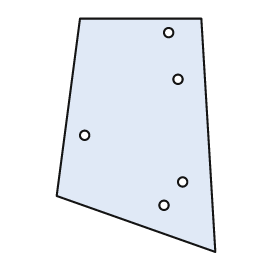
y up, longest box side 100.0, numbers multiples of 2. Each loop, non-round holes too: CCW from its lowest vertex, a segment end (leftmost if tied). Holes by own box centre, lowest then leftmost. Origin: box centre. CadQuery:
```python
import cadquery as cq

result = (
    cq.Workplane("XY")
    .moveTo(34.0, -50.0)
    .lineTo(28.0, 50.0)
    .lineTo(-24.0, 50.0)
    .lineTo(-34.0, -26.0)
    .close()
    .moveTo(12.0, -30.0)
    .circle(2.0)
    .moveTo(20.0, -20.0)
    .circle(2.0)
    .moveTo(-22.0, 0.0)
    .circle(2.0)
    .moveTo(18.0, 24.0)
    .circle(2.0)
    .moveTo(14.0, 44.0)
    .circle(2.0)
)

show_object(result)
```